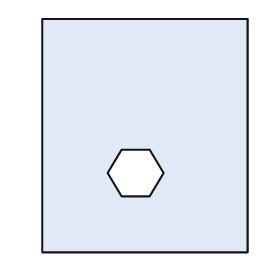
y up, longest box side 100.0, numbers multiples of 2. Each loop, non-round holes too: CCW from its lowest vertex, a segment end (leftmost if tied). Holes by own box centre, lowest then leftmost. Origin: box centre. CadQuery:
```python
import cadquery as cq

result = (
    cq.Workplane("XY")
    .moveTo(-44.0, -50.0)
    .lineTo(44.0, -50.0)
    .lineTo(44.0, 50.0)
    .lineTo(-44.0, 50.0)
    .close()
    .moveTo(-10.0, -26.0)
    .lineTo(2.0, -26.0)
    .lineTo(8.0, -16.0)
    .lineTo(2.0, -6.0)
    .lineTo(-10.0, -6.0)
    .lineTo(-16.0, -16.0)
    .close()
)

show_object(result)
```